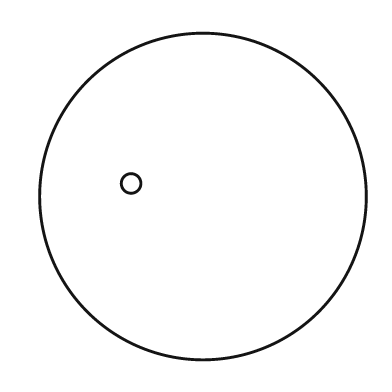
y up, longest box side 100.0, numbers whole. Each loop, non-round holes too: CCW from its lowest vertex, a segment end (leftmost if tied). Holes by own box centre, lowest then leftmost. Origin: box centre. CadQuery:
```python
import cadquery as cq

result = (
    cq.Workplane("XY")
    .moveTo(0.0, 0.0)
    .circle(50.0)
    .moveTo(-22.0, 4.0)
    .circle(3.0)
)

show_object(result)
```